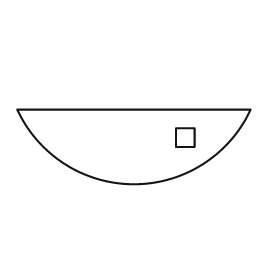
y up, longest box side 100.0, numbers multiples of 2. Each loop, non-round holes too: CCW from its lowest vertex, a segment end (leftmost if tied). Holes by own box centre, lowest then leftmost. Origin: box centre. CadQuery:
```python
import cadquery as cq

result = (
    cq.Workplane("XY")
    .moveTo(-50.0, 16.0)
    .threePointArc((0.0, -16.0), (50.0, 16.0))
    .close()
    .moveTo(18.0, 0.0)
    .lineTo(26.0, 0.0)
    .lineTo(26.0, 8.0)
    .lineTo(18.0, 8.0)
    .close()
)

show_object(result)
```